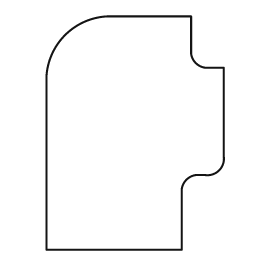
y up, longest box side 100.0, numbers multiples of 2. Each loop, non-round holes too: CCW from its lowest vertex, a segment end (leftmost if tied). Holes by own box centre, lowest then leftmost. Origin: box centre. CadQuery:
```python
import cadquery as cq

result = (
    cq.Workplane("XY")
    .moveTo(-38.0, -50.0)
    .lineTo(20.0, -50.0)
    .lineTo(20.0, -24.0)
    .threePointArc((22.0, -20.0), (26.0, -18.0))
    .lineTo(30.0, -18.0)
    .threePointArc((36.0, -16.0), (38.0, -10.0))
    .lineTo(38.0, 28.0)
    .lineTo(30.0, 28.0)
    .threePointArc((26.0, 30.0), (24.0, 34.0))
    .lineTo(24.0, 50.0)
    .lineTo(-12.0, 50.0)
    .threePointArc((-30.0, 42.0), (-38.0, 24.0))
    .close()
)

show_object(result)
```